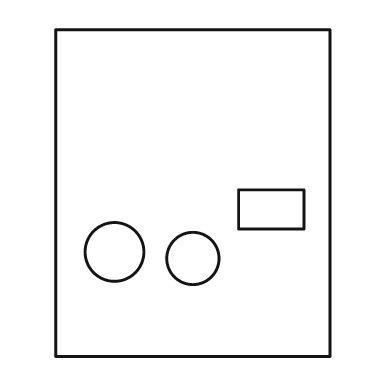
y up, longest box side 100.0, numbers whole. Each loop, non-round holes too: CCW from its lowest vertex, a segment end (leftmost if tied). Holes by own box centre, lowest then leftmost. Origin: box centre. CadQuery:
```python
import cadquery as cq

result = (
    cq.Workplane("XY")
    .moveTo(-42.0, -50.0)
    .lineTo(42.0, -50.0)
    .lineTo(42.0, 50.0)
    .lineTo(-42.0, 50.0)
    .close()
    .moveTo(0.0, -20.0)
    .circle(8.0)
    .moveTo(-24.0, -18.0)
    .circle(9.0)
    .moveTo(14.0, -11.0)
    .lineTo(34.0, -11.0)
    .lineTo(34.0, 1.0)
    .lineTo(14.0, 1.0)
    .close()
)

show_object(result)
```